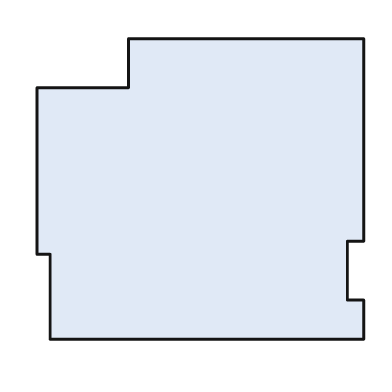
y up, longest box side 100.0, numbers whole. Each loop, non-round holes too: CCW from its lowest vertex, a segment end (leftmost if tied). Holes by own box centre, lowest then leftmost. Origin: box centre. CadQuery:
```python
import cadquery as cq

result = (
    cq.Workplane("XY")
    .moveTo(-46.0, -46.0)
    .lineTo(50.0, -46.0)
    .lineTo(50.0, -34.0)
    .lineTo(45.0, -34.0)
    .lineTo(45.0, -16.0)
    .lineTo(50.0, -16.0)
    .lineTo(50.0, 46.0)
    .lineTo(-22.0, 46.0)
    .lineTo(-22.0, 31.0)
    .lineTo(-50.0, 31.0)
    .lineTo(-50.0, -20.0)
    .lineTo(-46.0, -20.0)
    .close()
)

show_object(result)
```